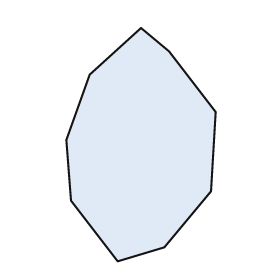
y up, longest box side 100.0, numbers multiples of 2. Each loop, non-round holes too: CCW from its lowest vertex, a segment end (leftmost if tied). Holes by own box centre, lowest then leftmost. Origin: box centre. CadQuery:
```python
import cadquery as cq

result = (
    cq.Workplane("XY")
    .moveTo(-10.0, -50.0)
    .lineTo(10.0, -44.0)
    .lineTo(30.0, -20.0)
    .lineTo(32.0, 14.0)
    .lineTo(12.0, 40.0)
    .lineTo(0.0, 50.0)
    .lineTo(-22.0, 30.0)
    .lineTo(-32.0, 2.0)
    .lineTo(-30.0, -24.0)
    .close()
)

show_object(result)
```